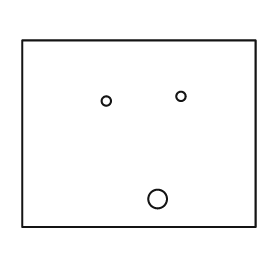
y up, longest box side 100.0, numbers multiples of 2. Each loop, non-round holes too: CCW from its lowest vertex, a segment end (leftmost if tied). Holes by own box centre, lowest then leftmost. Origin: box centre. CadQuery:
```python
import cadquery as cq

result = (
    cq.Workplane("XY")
    .moveTo(-50.0, -40.0)
    .lineTo(50.0, -40.0)
    .lineTo(50.0, 40.0)
    .lineTo(-50.0, 40.0)
    .close()
    .moveTo(8.0, -28.0)
    .circle(4.0)
    .moveTo(-14.0, 14.0)
    .circle(2.0)
    .moveTo(18.0, 16.0)
    .circle(2.0)
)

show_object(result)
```